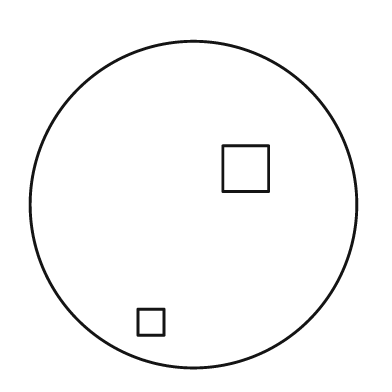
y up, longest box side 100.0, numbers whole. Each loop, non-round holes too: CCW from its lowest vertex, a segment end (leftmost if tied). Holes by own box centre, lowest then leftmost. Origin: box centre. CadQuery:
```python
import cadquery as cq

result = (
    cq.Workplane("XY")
    .moveTo(0.0, 0.0)
    .circle(50.0)
    .moveTo(-17.0, -40.0)
    .lineTo(-9.0, -40.0)
    .lineTo(-9.0, -32.0)
    .lineTo(-17.0, -32.0)
    .close()
    .moveTo(9.0, 4.0)
    .lineTo(23.0, 4.0)
    .lineTo(23.0, 18.0)
    .lineTo(9.0, 18.0)
    .close()
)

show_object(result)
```